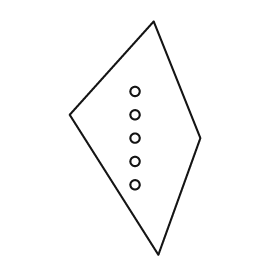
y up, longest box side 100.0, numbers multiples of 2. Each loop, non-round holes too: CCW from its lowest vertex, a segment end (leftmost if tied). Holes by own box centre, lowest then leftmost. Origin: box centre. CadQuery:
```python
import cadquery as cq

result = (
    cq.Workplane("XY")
    .moveTo(10.0, -50.0)
    .lineTo(28.0, 0.0)
    .lineTo(8.0, 50.0)
    .lineTo(-28.0, 10.0)
    .close()
    .moveTo(0.0, -20.0)
    .circle(2.0)
    .moveTo(0.0, -10.0)
    .circle(2.0)
    .moveTo(0.0, 0.0)
    .circle(2.0)
    .moveTo(0.0, 10.0)
    .circle(2.0)
    .moveTo(0.0, 20.0)
    .circle(2.0)
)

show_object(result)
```